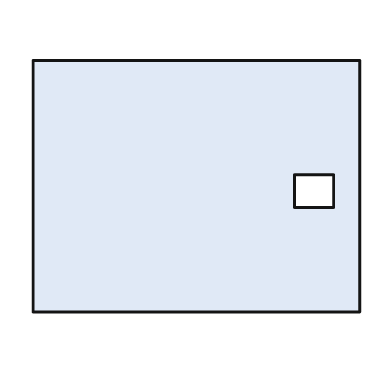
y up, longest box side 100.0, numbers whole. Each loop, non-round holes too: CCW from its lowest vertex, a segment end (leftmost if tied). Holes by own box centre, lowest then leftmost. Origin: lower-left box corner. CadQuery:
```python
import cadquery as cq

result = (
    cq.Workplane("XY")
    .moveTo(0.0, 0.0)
    .lineTo(100.0, 0.0)
    .lineTo(100.0, 77.0)
    .lineTo(0.0, 77.0)
    .close()
    .moveTo(80.0, 32.0)
    .lineTo(92.0, 32.0)
    .lineTo(92.0, 42.0)
    .lineTo(80.0, 42.0)
    .close()
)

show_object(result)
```